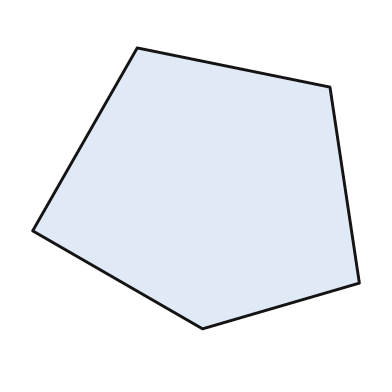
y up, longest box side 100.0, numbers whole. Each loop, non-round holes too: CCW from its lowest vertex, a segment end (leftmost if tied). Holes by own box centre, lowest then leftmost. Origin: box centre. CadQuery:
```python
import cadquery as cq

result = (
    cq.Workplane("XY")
    .moveTo(2.0, -43.0)
    .lineTo(50.0, -29.0)
    .lineTo(41.0, 31.0)
    .lineTo(-18.0, 43.0)
    .lineTo(-50.0, -13.0)
    .close()
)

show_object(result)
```